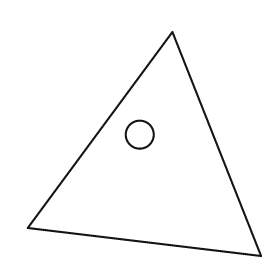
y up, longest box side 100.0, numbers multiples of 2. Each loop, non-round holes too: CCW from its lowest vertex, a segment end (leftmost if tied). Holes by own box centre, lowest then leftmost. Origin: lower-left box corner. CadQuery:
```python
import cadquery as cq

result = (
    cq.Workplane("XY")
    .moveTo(100.0, 0.0)
    .lineTo(62.0, 96.0)
    .lineTo(0.0, 12.0)
    .close()
    .moveTo(48.0, 52.0)
    .circle(6.0)
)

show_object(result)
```